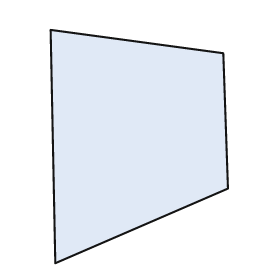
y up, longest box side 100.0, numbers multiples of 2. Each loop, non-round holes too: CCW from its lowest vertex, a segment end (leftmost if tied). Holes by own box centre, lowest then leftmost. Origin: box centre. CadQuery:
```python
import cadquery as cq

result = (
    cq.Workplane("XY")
    .moveTo(-36.0, -50.0)
    .lineTo(38.0, -18.0)
    .lineTo(36.0, 40.0)
    .lineTo(-38.0, 50.0)
    .close()
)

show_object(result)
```